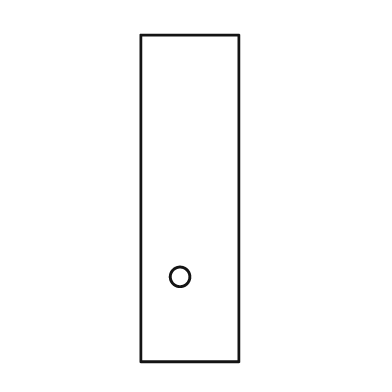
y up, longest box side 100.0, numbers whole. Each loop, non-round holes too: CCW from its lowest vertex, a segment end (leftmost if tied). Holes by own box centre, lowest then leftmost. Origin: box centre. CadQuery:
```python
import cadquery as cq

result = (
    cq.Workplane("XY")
    .moveTo(-15.0, -50.0)
    .lineTo(15.0, -50.0)
    .lineTo(15.0, 50.0)
    .lineTo(-15.0, 50.0)
    .close()
    .moveTo(-3.0, -24.0)
    .circle(3.0)
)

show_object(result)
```